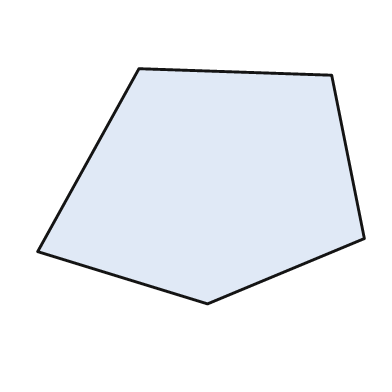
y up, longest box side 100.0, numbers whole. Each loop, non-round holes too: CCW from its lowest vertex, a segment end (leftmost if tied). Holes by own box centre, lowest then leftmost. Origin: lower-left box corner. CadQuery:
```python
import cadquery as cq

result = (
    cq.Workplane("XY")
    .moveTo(52.0, 0.0)
    .lineTo(100.0, 20.0)
    .lineTo(90.0, 70.0)
    .lineTo(31.0, 72.0)
    .lineTo(0.0, 16.0)
    .close()
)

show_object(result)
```